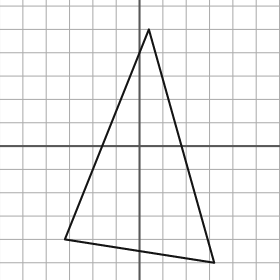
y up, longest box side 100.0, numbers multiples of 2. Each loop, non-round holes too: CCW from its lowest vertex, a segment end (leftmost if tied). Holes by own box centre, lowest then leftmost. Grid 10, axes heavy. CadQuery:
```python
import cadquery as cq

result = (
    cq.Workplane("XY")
    .moveTo(32.0, -50.0)
    .lineTo(4.0, 50.0)
    .lineTo(-32.0, -40.0)
    .close()
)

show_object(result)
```